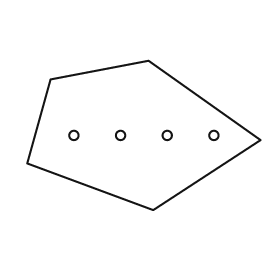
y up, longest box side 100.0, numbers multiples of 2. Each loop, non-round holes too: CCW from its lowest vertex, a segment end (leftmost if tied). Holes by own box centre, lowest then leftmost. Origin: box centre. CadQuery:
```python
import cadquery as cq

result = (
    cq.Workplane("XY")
    .moveTo(4.0, -32.0)
    .lineTo(50.0, -2.0)
    .lineTo(2.0, 32.0)
    .lineTo(-40.0, 24.0)
    .lineTo(-50.0, -12.0)
    .close()
    .moveTo(-30.0, 0.0)
    .circle(2.0)
    .moveTo(-10.0, 0.0)
    .circle(2.0)
    .moveTo(10.0, 0.0)
    .circle(2.0)
    .moveTo(30.0, 0.0)
    .circle(2.0)
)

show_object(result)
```